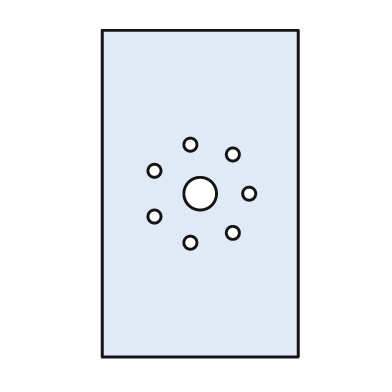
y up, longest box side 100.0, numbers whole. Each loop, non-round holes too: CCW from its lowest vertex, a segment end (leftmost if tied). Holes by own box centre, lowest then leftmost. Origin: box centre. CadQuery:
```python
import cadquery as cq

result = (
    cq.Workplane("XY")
    .moveTo(-30.0, -50.0)
    .lineTo(30.0, -50.0)
    .lineTo(30.0, 50.0)
    .lineTo(-30.0, 50.0)
    .close()
    .moveTo(-3.0, -15.0)
    .circle(2.0)
    .moveTo(10.0, -12.0)
    .circle(2.0)
    .moveTo(-14.0, -7.0)
    .circle(2.0)
    .moveTo(0.0, 0.0)
    .circle(5.0)
    .moveTo(15.0, 0.0)
    .circle(2.0)
    .moveTo(-14.0, 7.0)
    .circle(2.0)
    .moveTo(10.0, 12.0)
    .circle(2.0)
    .moveTo(-3.0, 15.0)
    .circle(2.0)
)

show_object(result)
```